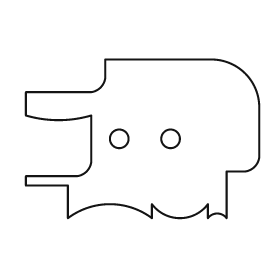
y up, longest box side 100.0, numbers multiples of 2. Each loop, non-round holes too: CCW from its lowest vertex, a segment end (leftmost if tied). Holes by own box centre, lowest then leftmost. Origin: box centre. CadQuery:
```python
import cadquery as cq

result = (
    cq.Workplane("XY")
    .moveTo(-32.0, -34.0)
    .threePointArc((-14.0, -28.0), (4.0, -34.0))
    .lineTo(4.0, -28.0)
    .threePointArc((16.0, -34.0), (28.0, -28.0))
    .lineTo(28.0, -34.0)
    .threePointArc((32.0, -32.0), (36.0, -34.0))
    .lineTo(36.0, -14.0)
    .lineTo(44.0, -14.0)
    .threePointArc((48.0, -12.0), (50.0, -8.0))
    .lineTo(50.0, 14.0)
    .threePointArc((44.0, 28.0), (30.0, 34.0))
    .lineTo(-16.0, 34.0)
    .lineTo(-16.0, 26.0)
    .threePointArc((-18.0, 22.0), (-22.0, 20.0))
    .lineTo(-50.0, 20.0)
    .lineTo(-50.0, 10.0)
    .threePointArc((-36.0, 8.0), (-22.0, 10.0))
    .lineTo(-22.0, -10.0)
    .threePointArc((-24.0, -14.0), (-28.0, -16.0))
    .lineTo(-50.0, -16.0)
    .lineTo(-50.0, -20.0)
    .lineTo(-32.0, -20.0)
    .close()
    .moveTo(-10.0, 0.0)
    .circle(4.0)
    .moveTo(12.0, 0.0)
    .circle(4.0)
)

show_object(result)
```